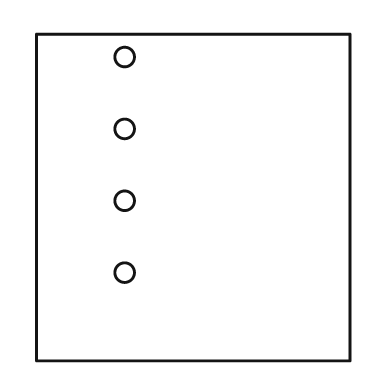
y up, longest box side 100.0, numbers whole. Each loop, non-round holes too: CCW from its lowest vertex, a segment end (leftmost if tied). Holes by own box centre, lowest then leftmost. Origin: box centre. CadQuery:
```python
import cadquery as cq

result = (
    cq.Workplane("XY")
    .moveTo(-48.0, -50.0)
    .lineTo(48.0, -50.0)
    .lineTo(48.0, 50.0)
    .lineTo(-48.0, 50.0)
    .close()
    .moveTo(-21.0, -23.0)
    .circle(3.0)
    .moveTo(-21.0, -1.0)
    .circle(3.0)
    .moveTo(-21.0, 21.0)
    .circle(3.0)
    .moveTo(-21.0, 43.0)
    .circle(3.0)
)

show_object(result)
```